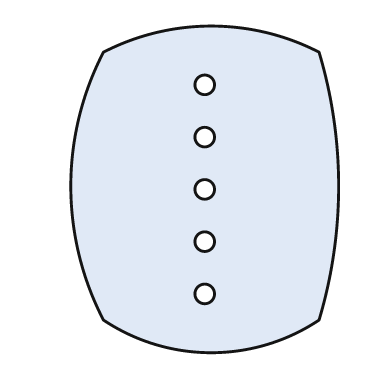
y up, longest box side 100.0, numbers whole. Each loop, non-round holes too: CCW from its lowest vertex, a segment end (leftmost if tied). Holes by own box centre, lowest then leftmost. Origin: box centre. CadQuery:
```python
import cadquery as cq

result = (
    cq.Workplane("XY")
    .moveTo(-31.0, -40.0)
    .threePointArc((2.0, -50.0), (35.0, -40.0))
    .threePointArc((41.0, 1.0), (35.0, 42.0))
    .threePointArc((2.0, 50.0), (-31.0, 42.0))
    .threePointArc((-41.0, 1.0), (-31.0, -40.0))
    .close()
    .moveTo(0.0, -32.0)
    .circle(3.0)
    .moveTo(0.0, -16.0)
    .circle(3.0)
    .moveTo(0.0, 0.0)
    .circle(3.0)
    .moveTo(0.0, 16.0)
    .circle(3.0)
    .moveTo(0.0, 32.0)
    .circle(3.0)
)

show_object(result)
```